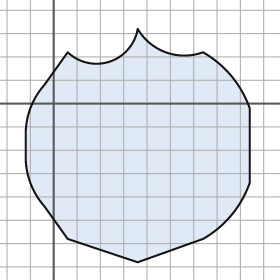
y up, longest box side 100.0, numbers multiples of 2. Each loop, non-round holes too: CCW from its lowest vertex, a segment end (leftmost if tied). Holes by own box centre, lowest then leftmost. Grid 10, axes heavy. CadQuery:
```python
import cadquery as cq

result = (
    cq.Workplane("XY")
    .moveTo(36.0, -68.0)
    .lineTo(64.0, -58.0)
    .threePointArc((76.0, -48.0), (84.0, -34.0))
    .lineTo(84.0, -2.0)
    .threePointArc((76.0, 12.0), (64.0, 22.0))
    .threePointArc((48.0, 22.0), (36.0, 32.0))
    .threePointArc((24.0, 18.0), (6.0, 22.0))
    .lineTo(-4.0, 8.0)
    .threePointArc((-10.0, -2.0), (-12.0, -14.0))
    .lineTo(-12.0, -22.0)
    .threePointArc((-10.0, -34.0), (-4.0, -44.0))
    .lineTo(6.0, -58.0)
    .close()
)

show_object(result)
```